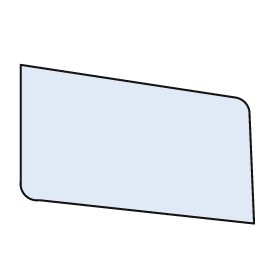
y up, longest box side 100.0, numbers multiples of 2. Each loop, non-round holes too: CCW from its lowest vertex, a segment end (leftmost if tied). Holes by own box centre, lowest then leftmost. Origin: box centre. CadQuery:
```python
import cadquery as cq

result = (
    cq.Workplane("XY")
    .moveTo(50.0, -34.0)
    .lineTo(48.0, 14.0)
    .threePointArc((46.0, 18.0), (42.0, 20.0))
    .lineTo(-50.0, 34.0)
    .lineTo(-50.0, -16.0)
    .threePointArc((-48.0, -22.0), (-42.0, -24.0))
    .close()
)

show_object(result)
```